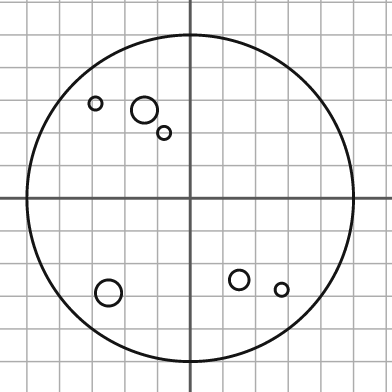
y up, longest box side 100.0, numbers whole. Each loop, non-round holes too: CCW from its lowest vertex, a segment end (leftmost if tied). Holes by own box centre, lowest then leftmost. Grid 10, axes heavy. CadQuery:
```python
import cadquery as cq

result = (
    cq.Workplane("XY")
    .moveTo(0.0, 0.0)
    .circle(50.0)
    .moveTo(-25.0, -29.0)
    .circle(4.0)
    .moveTo(28.0, -28.0)
    .circle(2.0)
    .moveTo(15.0, -25.0)
    .circle(3.0)
    .moveTo(-8.0, 20.0)
    .circle(2.0)
    .moveTo(-14.0, 27.0)
    .circle(4.0)
    .moveTo(-29.0, 29.0)
    .circle(2.0)
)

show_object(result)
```